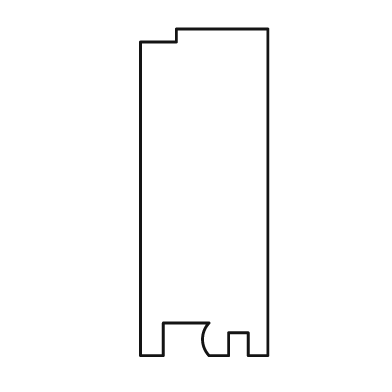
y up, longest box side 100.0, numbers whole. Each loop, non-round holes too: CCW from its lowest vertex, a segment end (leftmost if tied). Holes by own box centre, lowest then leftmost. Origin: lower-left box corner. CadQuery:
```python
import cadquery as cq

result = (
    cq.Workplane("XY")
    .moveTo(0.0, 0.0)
    .lineTo(7.0, 0.0)
    .lineTo(7.0, 10.0)
    .lineTo(21.0, 10.0)
    .threePointArc((19.0, 5.0), (21.0, 0.0))
    .lineTo(27.0, 0.0)
    .lineTo(27.0, 7.0)
    .lineTo(33.0, 7.0)
    .lineTo(33.0, 0.0)
    .lineTo(39.0, 0.0)
    .lineTo(39.0, 100.0)
    .lineTo(11.0, 100.0)
    .lineTo(11.0, 96.0)
    .lineTo(0.0, 96.0)
    .close()
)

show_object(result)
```